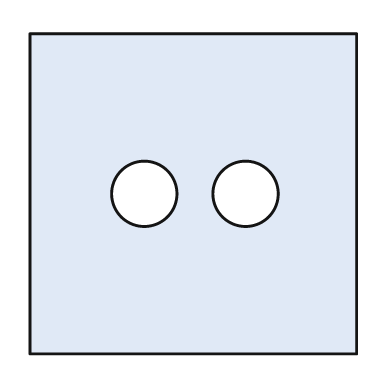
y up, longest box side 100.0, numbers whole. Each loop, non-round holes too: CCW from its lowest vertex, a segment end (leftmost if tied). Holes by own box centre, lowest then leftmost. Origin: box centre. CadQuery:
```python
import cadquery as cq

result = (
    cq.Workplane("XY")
    .moveTo(-50.0, -49.0)
    .lineTo(50.0, -49.0)
    .lineTo(50.0, 49.0)
    .lineTo(-50.0, 49.0)
    .close()
    .moveTo(-15.0, 0.0)
    .circle(10.0)
    .moveTo(16.0, 0.0)
    .circle(10.0)
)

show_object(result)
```